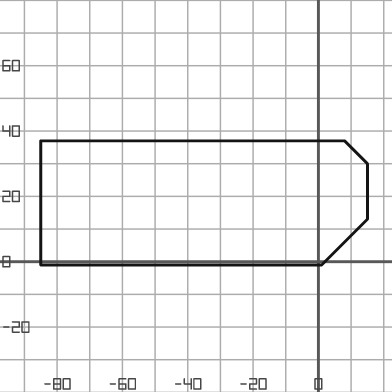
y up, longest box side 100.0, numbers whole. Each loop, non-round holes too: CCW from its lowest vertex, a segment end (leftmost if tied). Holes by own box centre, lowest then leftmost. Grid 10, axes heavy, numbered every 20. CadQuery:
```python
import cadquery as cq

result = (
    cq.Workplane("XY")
    .moveTo(-85.0, -1.0)
    .lineTo(1.0, -1.0)
    .lineTo(15.0, 13.0)
    .lineTo(15.0, 30.0)
    .lineTo(8.0, 37.0)
    .lineTo(-85.0, 37.0)
    .close()
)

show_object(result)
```